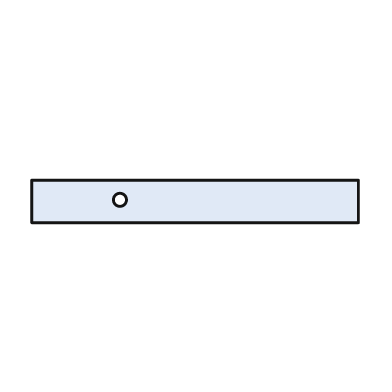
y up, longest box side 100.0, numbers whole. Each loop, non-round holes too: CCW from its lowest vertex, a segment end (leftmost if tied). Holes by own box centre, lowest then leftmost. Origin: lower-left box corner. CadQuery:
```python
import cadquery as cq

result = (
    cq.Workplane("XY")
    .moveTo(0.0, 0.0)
    .lineTo(100.0, 0.0)
    .lineTo(100.0, 13.0)
    .lineTo(0.0, 13.0)
    .close()
    .moveTo(27.0, 7.0)
    .circle(2.0)
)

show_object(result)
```